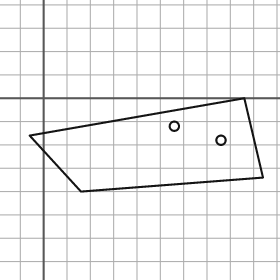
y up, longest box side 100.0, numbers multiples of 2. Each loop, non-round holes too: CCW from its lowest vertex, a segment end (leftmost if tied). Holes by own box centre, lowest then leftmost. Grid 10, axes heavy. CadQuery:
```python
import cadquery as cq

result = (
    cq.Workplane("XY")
    .moveTo(16.0, -40.0)
    .lineTo(94.0, -34.0)
    .lineTo(86.0, 0.0)
    .lineTo(-6.0, -16.0)
    .close()
    .moveTo(76.0, -18.0)
    .circle(2.0)
    .moveTo(56.0, -12.0)
    .circle(2.0)
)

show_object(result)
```